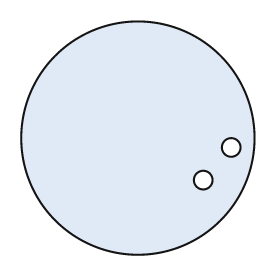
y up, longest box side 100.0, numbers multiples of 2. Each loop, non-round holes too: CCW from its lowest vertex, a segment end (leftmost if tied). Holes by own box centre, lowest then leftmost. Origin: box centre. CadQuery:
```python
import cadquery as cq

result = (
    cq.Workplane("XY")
    .moveTo(0.0, 0.0)
    .circle(50.0)
    .moveTo(28.0, -18.0)
    .circle(4.0)
    .moveTo(40.0, -4.0)
    .circle(4.0)
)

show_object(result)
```